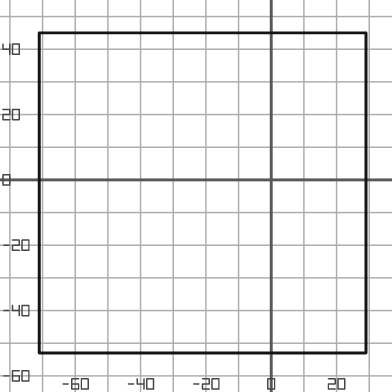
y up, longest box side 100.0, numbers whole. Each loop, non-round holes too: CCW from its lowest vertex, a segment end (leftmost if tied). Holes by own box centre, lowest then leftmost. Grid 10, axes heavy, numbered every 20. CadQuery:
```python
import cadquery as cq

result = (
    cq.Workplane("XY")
    .moveTo(-71.0, -53.0)
    .lineTo(29.0, -53.0)
    .lineTo(29.0, 45.0)
    .lineTo(-71.0, 45.0)
    .close()
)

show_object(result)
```